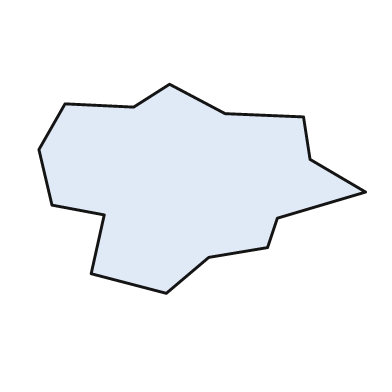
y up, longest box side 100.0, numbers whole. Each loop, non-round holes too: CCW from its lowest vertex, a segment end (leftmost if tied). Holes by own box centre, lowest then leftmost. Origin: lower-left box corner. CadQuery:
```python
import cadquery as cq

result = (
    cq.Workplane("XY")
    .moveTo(39.0, 0.0)
    .lineTo(52.0, 11.0)
    .lineTo(70.0, 14.0)
    .lineTo(73.0, 23.0)
    .lineTo(100.0, 31.0)
    .lineTo(83.0, 41.0)
    .lineTo(81.0, 54.0)
    .lineTo(57.0, 55.0)
    .lineTo(40.0, 64.0)
    .lineTo(29.0, 57.0)
    .lineTo(8.0, 58.0)
    .lineTo(0.0, 44.0)
    .lineTo(4.0, 27.0)
    .lineTo(20.0, 24.0)
    .lineTo(16.0, 6.0)
    .close()
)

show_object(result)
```